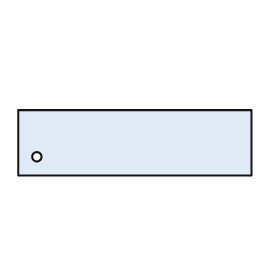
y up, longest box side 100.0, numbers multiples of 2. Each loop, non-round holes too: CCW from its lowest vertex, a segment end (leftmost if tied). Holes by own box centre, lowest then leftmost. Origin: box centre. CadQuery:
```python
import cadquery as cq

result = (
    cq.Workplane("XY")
    .moveTo(-50.0, -14.0)
    .lineTo(50.0, -14.0)
    .lineTo(50.0, 14.0)
    .lineTo(-50.0, 14.0)
    .close()
    .moveTo(-42.0, -6.0)
    .circle(2.0)
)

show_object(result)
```